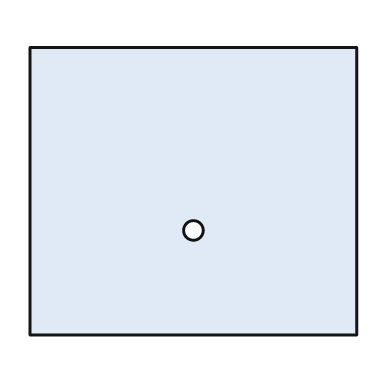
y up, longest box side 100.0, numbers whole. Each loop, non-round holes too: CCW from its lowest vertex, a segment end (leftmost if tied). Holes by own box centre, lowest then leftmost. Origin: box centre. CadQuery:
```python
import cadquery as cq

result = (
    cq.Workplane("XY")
    .moveTo(-50.0, -44.0)
    .lineTo(50.0, -44.0)
    .lineTo(50.0, 44.0)
    .lineTo(-50.0, 44.0)
    .close()
    .moveTo(0.0, -12.0)
    .circle(3.0)
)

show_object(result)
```